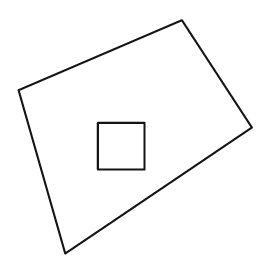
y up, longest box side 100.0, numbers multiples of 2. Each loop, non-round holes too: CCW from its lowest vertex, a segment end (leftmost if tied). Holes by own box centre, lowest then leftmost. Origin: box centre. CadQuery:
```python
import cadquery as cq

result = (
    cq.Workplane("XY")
    .moveTo(-30.0, -50.0)
    .lineTo(50.0, 4.0)
    .lineTo(20.0, 50.0)
    .lineTo(-50.0, 20.0)
    .close()
    .moveTo(-16.0, -14.0)
    .lineTo(4.0, -14.0)
    .lineTo(4.0, 6.0)
    .lineTo(-16.0, 6.0)
    .close()
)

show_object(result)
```